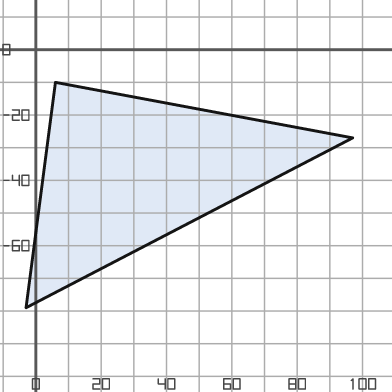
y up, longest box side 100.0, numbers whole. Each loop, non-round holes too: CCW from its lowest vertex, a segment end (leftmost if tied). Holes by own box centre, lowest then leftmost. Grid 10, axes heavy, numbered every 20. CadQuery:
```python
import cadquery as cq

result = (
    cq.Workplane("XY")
    .moveTo(-3.0, -79.0)
    .lineTo(97.0, -27.0)
    .lineTo(6.0, -10.0)
    .close()
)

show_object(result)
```